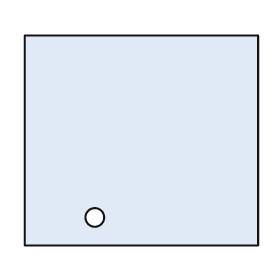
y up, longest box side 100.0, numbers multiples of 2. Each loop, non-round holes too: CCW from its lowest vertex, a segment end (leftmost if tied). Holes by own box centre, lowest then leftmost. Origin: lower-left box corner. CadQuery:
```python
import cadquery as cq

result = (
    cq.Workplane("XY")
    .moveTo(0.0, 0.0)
    .lineTo(100.0, 0.0)
    .lineTo(100.0, 90.0)
    .lineTo(0.0, 90.0)
    .close()
    .moveTo(30.0, 12.0)
    .circle(4.0)
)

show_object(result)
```